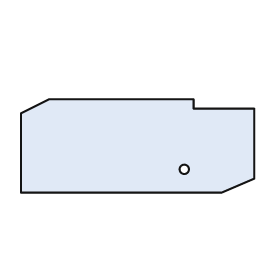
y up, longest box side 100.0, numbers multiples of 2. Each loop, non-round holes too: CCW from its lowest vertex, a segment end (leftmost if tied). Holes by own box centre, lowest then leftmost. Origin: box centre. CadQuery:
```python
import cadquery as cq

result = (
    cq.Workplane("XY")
    .moveTo(-50.0, -20.0)
    .lineTo(36.0, -20.0)
    .lineTo(50.0, -14.0)
    .lineTo(50.0, 16.0)
    .lineTo(24.0, 16.0)
    .lineTo(24.0, 20.0)
    .lineTo(-38.0, 20.0)
    .lineTo(-50.0, 14.0)
    .close()
    .moveTo(20.0, -10.0)
    .circle(2.0)
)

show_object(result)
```